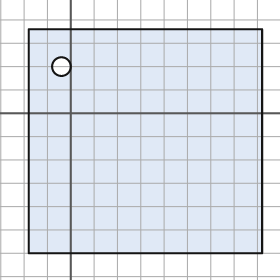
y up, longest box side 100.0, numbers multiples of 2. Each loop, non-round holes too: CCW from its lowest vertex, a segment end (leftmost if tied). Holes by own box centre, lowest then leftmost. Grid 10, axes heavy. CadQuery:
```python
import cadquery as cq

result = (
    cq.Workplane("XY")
    .moveTo(-18.0, -60.0)
    .lineTo(82.0, -60.0)
    .lineTo(82.0, 36.0)
    .lineTo(-18.0, 36.0)
    .close()
    .moveTo(-4.0, 20.0)
    .circle(4.0)
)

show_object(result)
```